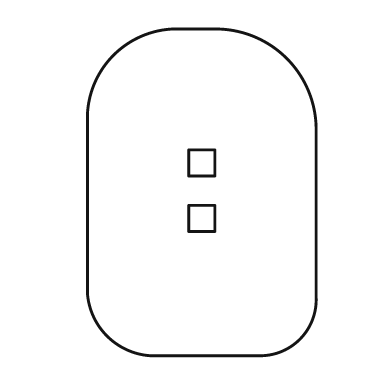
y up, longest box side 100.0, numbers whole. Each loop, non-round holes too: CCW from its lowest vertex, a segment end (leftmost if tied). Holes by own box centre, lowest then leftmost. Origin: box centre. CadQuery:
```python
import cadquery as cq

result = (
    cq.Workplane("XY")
    .moveTo(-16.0, -50.0)
    .lineTo(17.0, -50.0)
    .threePointArc((30.0, -45.0), (35.0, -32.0))
    .lineTo(35.0, 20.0)
    .threePointArc((26.0, 41.0), (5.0, 50.0))
    .lineTo(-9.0, 50.0)
    .threePointArc((-27.0, 42.0), (-35.0, 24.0))
    .lineTo(-35.0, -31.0)
    .threePointArc((-29.0, -44.0), (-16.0, -50.0))
    .close()
    .moveTo(-4.0, -12.0)
    .lineTo(4.0, -12.0)
    .lineTo(4.0, -4.0)
    .lineTo(-4.0, -4.0)
    .close()
    .moveTo(-4.0, 5.0)
    .lineTo(4.0, 5.0)
    .lineTo(4.0, 13.0)
    .lineTo(-4.0, 13.0)
    .close()
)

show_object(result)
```